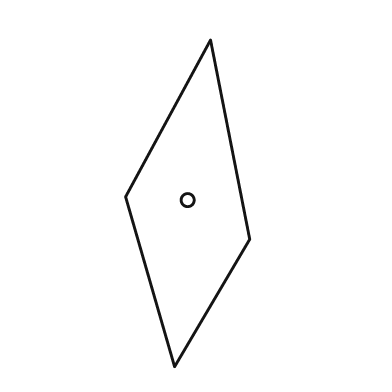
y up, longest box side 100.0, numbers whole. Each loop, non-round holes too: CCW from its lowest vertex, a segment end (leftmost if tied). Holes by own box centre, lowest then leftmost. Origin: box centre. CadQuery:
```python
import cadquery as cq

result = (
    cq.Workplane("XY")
    .moveTo(-4.0, -50.0)
    .lineTo(19.0, -11.0)
    .lineTo(7.0, 50.0)
    .lineTo(-19.0, 2.0)
    .close()
    .moveTo(0.0, 1.0)
    .circle(2.0)
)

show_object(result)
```